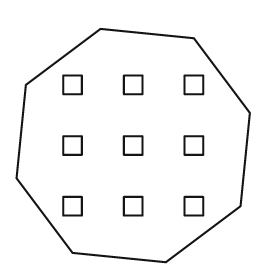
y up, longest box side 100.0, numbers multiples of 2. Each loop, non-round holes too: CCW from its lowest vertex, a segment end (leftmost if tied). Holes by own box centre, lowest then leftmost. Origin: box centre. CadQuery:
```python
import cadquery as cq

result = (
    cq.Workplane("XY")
    .moveTo(14.0, -50.0)
    .lineTo(46.0, -26.0)
    .lineTo(50.0, 14.0)
    .lineTo(26.0, 46.0)
    .lineTo(-14.0, 50.0)
    .lineTo(-46.0, 26.0)
    .lineTo(-50.0, -14.0)
    .lineTo(-26.0, -46.0)
    .close()
    .moveTo(-30.0, -30.0)
    .lineTo(-22.0, -30.0)
    .lineTo(-22.0, -22.0)
    .lineTo(-30.0, -22.0)
    .close()
    .moveTo(-4.0, -30.0)
    .lineTo(4.0, -30.0)
    .lineTo(4.0, -22.0)
    .lineTo(-4.0, -22.0)
    .close()
    .moveTo(22.0, -30.0)
    .lineTo(30.0, -30.0)
    .lineTo(30.0, -22.0)
    .lineTo(22.0, -22.0)
    .close()
    .moveTo(-30.0, -4.0)
    .lineTo(-22.0, -4.0)
    .lineTo(-22.0, 4.0)
    .lineTo(-30.0, 4.0)
    .close()
    .moveTo(-4.0, -4.0)
    .lineTo(4.0, -4.0)
    .lineTo(4.0, 4.0)
    .lineTo(-4.0, 4.0)
    .close()
    .moveTo(22.0, -4.0)
    .lineTo(30.0, -4.0)
    .lineTo(30.0, 4.0)
    .lineTo(22.0, 4.0)
    .close()
    .moveTo(-30.0, 22.0)
    .lineTo(-22.0, 22.0)
    .lineTo(-22.0, 30.0)
    .lineTo(-30.0, 30.0)
    .close()
    .moveTo(-4.0, 22.0)
    .lineTo(4.0, 22.0)
    .lineTo(4.0, 30.0)
    .lineTo(-4.0, 30.0)
    .close()
    .moveTo(22.0, 22.0)
    .lineTo(30.0, 22.0)
    .lineTo(30.0, 30.0)
    .lineTo(22.0, 30.0)
    .close()
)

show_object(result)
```